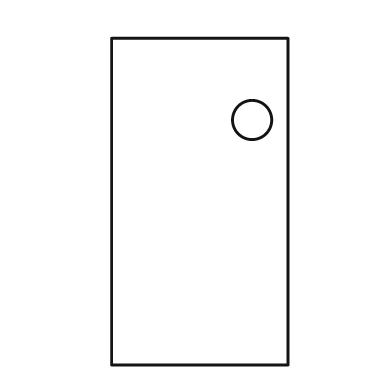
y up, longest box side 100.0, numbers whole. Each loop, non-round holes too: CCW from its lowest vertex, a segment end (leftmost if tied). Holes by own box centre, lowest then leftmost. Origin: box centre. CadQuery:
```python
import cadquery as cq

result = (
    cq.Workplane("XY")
    .moveTo(-27.0, -50.0)
    .lineTo(27.0, -50.0)
    .lineTo(27.0, 50.0)
    .lineTo(-27.0, 50.0)
    .close()
    .moveTo(16.0, 25.0)
    .circle(6.0)
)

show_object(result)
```